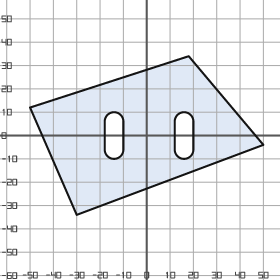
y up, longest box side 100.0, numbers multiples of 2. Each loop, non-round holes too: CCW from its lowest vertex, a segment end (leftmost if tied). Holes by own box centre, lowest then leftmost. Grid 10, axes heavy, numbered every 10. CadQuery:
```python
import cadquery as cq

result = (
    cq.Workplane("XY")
    .moveTo(-30.0, -34.0)
    .lineTo(50.0, -4.0)
    .lineTo(18.0, 34.0)
    .lineTo(-50.0, 12.0)
    .close()
    .moveTo(-18.0, -6.0)
    .threePointArc((-14.0, -10.0), (-10.0, -6.0))
    .lineTo(-10.0, 6.0)
    .threePointArc((-14.0, 10.0), (-18.0, 6.0))
    .close()
    .moveTo(12.0, -6.0)
    .threePointArc((16.0, -10.0), (20.0, -6.0))
    .lineTo(20.0, 6.0)
    .threePointArc((16.0, 10.0), (12.0, 6.0))
    .close()
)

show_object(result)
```